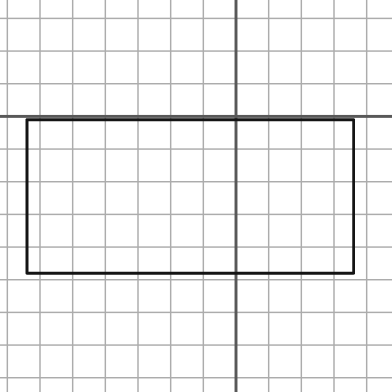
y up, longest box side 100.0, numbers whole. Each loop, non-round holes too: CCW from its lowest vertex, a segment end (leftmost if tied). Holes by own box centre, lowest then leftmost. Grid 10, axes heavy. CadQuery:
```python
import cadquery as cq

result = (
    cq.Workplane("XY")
    .moveTo(-64.0, -48.0)
    .lineTo(36.0, -48.0)
    .lineTo(36.0, -1.0)
    .lineTo(-64.0, -1.0)
    .close()
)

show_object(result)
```